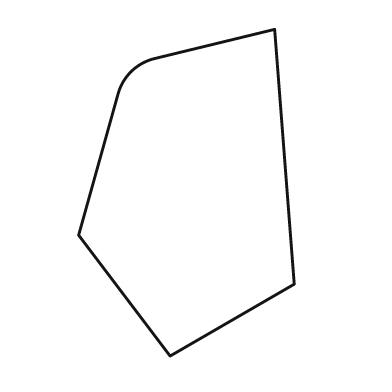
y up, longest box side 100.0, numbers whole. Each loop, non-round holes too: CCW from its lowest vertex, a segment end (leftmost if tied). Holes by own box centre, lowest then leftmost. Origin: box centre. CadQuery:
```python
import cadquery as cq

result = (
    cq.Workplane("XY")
    .moveTo(-5.0, -50.0)
    .lineTo(33.0, -28.0)
    .lineTo(27.0, 50.0)
    .lineTo(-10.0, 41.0)
    .threePointArc((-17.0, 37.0), (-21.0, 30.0))
    .lineTo(-33.0, -13.0)
    .close()
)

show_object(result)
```